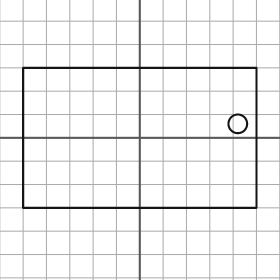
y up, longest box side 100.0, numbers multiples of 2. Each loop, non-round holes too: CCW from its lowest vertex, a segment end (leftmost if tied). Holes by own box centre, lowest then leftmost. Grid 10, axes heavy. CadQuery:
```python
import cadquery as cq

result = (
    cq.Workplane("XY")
    .moveTo(-50.0, -30.0)
    .lineTo(50.0, -30.0)
    .lineTo(50.0, 30.0)
    .lineTo(-50.0, 30.0)
    .close()
    .moveTo(42.0, 6.0)
    .circle(4.0)
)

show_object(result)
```